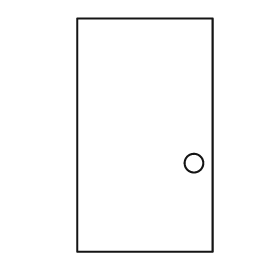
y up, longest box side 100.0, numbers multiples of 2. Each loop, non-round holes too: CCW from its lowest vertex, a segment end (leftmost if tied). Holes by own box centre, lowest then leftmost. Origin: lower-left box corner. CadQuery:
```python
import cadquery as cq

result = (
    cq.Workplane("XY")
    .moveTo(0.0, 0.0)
    .lineTo(58.0, 0.0)
    .lineTo(58.0, 100.0)
    .lineTo(0.0, 100.0)
    .close()
    .moveTo(50.0, 38.0)
    .circle(4.0)
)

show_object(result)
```